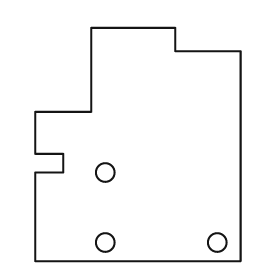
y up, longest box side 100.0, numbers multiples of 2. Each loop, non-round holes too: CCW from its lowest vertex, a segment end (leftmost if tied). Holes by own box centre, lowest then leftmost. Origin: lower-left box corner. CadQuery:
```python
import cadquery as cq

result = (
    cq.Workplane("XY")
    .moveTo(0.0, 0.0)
    .lineTo(88.0, 0.0)
    .lineTo(88.0, 90.0)
    .lineTo(60.0, 90.0)
    .lineTo(60.0, 100.0)
    .lineTo(24.0, 100.0)
    .lineTo(24.0, 64.0)
    .lineTo(0.0, 64.0)
    .lineTo(0.0, 46.0)
    .lineTo(12.0, 46.0)
    .lineTo(12.0, 38.0)
    .lineTo(0.0, 38.0)
    .close()
    .moveTo(30.0, 8.0)
    .circle(4.0)
    .moveTo(78.0, 8.0)
    .circle(4.0)
    .moveTo(30.0, 38.0)
    .circle(4.0)
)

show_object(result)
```